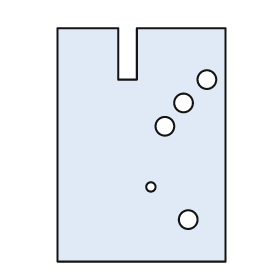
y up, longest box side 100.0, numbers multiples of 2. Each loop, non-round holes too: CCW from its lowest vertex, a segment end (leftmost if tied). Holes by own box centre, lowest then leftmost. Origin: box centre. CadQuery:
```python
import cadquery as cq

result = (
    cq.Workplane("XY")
    .moveTo(-36.0, -50.0)
    .lineTo(36.0, -50.0)
    .lineTo(36.0, 50.0)
    .lineTo(-2.0, 50.0)
    .lineTo(-2.0, 28.0)
    .lineTo(-10.0, 28.0)
    .lineTo(-10.0, 50.0)
    .lineTo(-36.0, 50.0)
    .close()
    .moveTo(20.0, -32.0)
    .circle(4.0)
    .moveTo(4.0, -18.0)
    .circle(2.0)
    .moveTo(10.0, 8.0)
    .circle(4.0)
    .moveTo(18.0, 18.0)
    .circle(4.0)
    .moveTo(28.0, 28.0)
    .circle(4.0)
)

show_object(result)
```